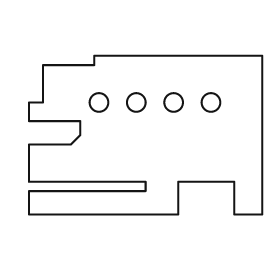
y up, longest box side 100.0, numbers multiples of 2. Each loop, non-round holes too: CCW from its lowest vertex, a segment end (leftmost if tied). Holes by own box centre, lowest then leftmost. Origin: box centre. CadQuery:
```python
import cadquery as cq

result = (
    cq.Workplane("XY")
    .moveTo(-50.0, -34.0)
    .lineTo(14.0, -34.0)
    .lineTo(14.0, -20.0)
    .lineTo(38.0, -20.0)
    .lineTo(38.0, -34.0)
    .lineTo(50.0, -34.0)
    .lineTo(50.0, 34.0)
    .lineTo(-22.0, 34.0)
    .lineTo(-22.0, 30.0)
    .lineTo(-44.0, 30.0)
    .lineTo(-44.0, 14.0)
    .lineTo(-50.0, 14.0)
    .lineTo(-50.0, 6.0)
    .lineTo(-28.0, 6.0)
    .lineTo(-28.0, 0.0)
    .lineTo(-32.0, -4.0)
    .lineTo(-50.0, -4.0)
    .lineTo(-50.0, -20.0)
    .lineTo(0.0, -20.0)
    .lineTo(0.0, -24.0)
    .lineTo(-50.0, -24.0)
    .close()
    .moveTo(-20.0, 14.0)
    .circle(4.0)
    .moveTo(-4.0, 14.0)
    .circle(4.0)
    .moveTo(12.0, 14.0)
    .circle(4.0)
    .moveTo(28.0, 14.0)
    .circle(4.0)
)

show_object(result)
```